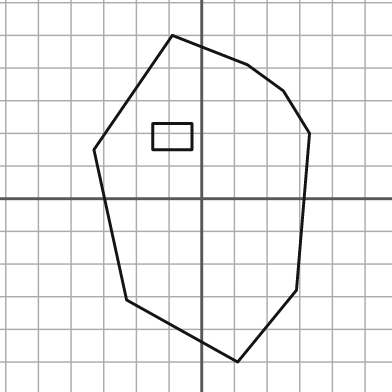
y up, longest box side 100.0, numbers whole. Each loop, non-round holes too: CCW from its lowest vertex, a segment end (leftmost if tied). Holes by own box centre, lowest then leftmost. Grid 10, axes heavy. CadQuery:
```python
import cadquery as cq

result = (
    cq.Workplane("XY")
    .moveTo(11.0, -50.0)
    .lineTo(29.0, -28.0)
    .lineTo(33.0, 20.0)
    .lineTo(25.0, 33.0)
    .lineTo(14.0, 41.0)
    .lineTo(-9.0, 50.0)
    .lineTo(-33.0, 15.0)
    .lineTo(-23.0, -31.0)
    .close()
    .moveTo(-15.0, 15.0)
    .lineTo(-3.0, 15.0)
    .lineTo(-3.0, 23.0)
    .lineTo(-15.0, 23.0)
    .close()
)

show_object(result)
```